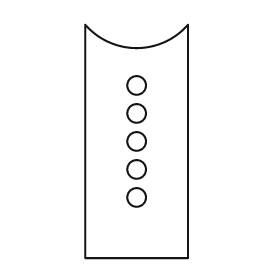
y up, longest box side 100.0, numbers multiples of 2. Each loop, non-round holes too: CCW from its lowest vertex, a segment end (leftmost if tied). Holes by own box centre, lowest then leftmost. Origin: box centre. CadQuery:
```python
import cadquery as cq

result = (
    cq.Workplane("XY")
    .moveTo(-22.0, -50.0)
    .lineTo(22.0, -50.0)
    .lineTo(22.0, 50.0)
    .threePointArc((0.0, 40.0), (-22.0, 50.0))
    .close()
    .moveTo(0.0, -24.0)
    .circle(4.0)
    .moveTo(0.0, -12.0)
    .circle(4.0)
    .moveTo(0.0, 0.0)
    .circle(4.0)
    .moveTo(0.0, 12.0)
    .circle(4.0)
    .moveTo(0.0, 24.0)
    .circle(4.0)
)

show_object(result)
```